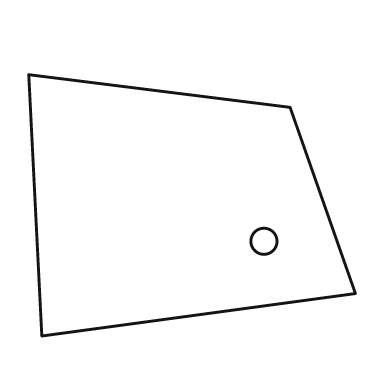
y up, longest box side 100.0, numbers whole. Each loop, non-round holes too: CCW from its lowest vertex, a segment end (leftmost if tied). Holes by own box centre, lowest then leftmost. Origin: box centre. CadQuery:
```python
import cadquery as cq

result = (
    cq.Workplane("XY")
    .moveTo(-46.0, -40.0)
    .lineTo(50.0, -27.0)
    .lineTo(30.0, 30.0)
    .lineTo(-50.0, 40.0)
    .close()
    .moveTo(22.0, -11.0)
    .circle(4.0)
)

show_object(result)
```